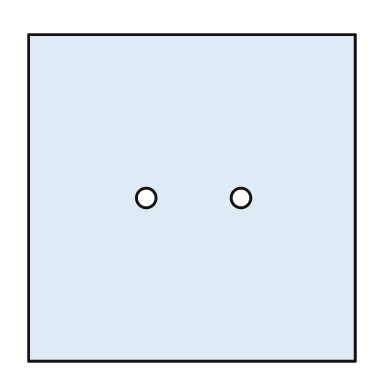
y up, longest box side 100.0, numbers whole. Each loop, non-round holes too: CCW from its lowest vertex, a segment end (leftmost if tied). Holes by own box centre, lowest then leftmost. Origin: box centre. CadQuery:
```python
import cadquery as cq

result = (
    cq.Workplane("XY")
    .moveTo(-50.0, -50.0)
    .lineTo(50.0, -50.0)
    .lineTo(50.0, 50.0)
    .lineTo(-50.0, 50.0)
    .close()
    .moveTo(-14.0, 0.0)
    .circle(3.0)
    .moveTo(15.0, 0.0)
    .circle(3.0)
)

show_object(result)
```